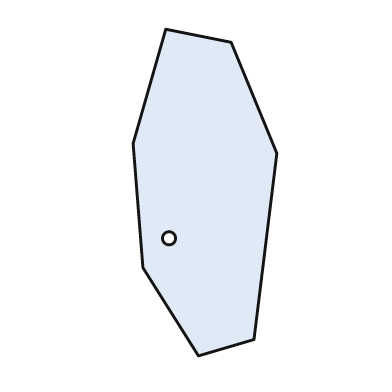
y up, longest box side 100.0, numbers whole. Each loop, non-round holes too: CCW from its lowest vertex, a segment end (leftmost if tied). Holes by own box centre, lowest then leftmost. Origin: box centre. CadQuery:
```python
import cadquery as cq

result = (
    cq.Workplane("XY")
    .moveTo(-2.0, -50.0)
    .lineTo(15.0, -45.0)
    .lineTo(22.0, 12.0)
    .lineTo(8.0, 46.0)
    .lineTo(-12.0, 50.0)
    .lineTo(-22.0, 15.0)
    .lineTo(-19.0, -23.0)
    .close()
    .moveTo(-11.0, -14.0)
    .circle(2.0)
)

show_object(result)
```